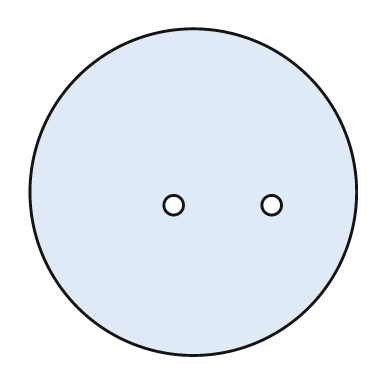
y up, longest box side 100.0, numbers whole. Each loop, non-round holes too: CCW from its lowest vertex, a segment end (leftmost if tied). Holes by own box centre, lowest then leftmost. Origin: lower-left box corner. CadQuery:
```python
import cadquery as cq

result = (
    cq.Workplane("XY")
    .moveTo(50.0, 50.0)
    .circle(50.0)
    .moveTo(44.0, 46.0)
    .circle(3.0)
    .moveTo(74.0, 46.0)
    .circle(3.0)
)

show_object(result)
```